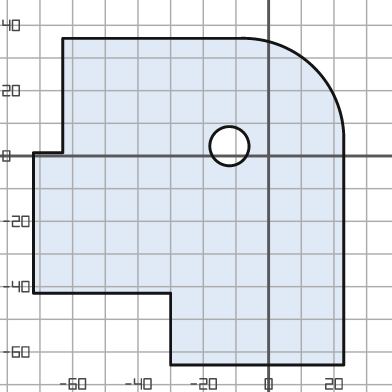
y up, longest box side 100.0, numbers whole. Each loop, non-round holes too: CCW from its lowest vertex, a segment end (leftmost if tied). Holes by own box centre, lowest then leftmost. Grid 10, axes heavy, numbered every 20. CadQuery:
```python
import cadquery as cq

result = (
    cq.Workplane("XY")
    .moveTo(-30.0, -64.0)
    .lineTo(23.0, -64.0)
    .lineTo(23.0, 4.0)
    .threePointArc((14.0, 27.0), (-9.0, 36.0))
    .lineTo(-63.0, 36.0)
    .lineTo(-63.0, 1.0)
    .lineTo(-72.0, 1.0)
    .lineTo(-72.0, -42.0)
    .lineTo(-30.0, -42.0)
    .close()
    .moveTo(-12.0, 3.0)
    .circle(6.0)
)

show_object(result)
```